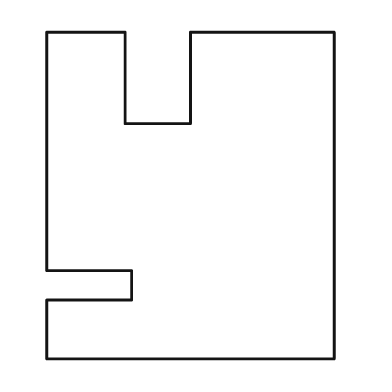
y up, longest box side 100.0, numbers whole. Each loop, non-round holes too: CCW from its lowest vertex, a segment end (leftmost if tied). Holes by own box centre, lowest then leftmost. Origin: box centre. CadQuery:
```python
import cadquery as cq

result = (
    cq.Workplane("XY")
    .moveTo(-44.0, -50.0)
    .lineTo(44.0, -50.0)
    .lineTo(44.0, 50.0)
    .lineTo(0.0, 50.0)
    .lineTo(0.0, 22.0)
    .lineTo(-20.0, 22.0)
    .lineTo(-20.0, 50.0)
    .lineTo(-44.0, 50.0)
    .lineTo(-44.0, -23.0)
    .lineTo(-18.0, -23.0)
    .lineTo(-18.0, -32.0)
    .lineTo(-44.0, -32.0)
    .close()
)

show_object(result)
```